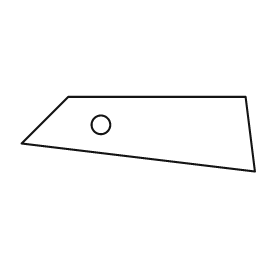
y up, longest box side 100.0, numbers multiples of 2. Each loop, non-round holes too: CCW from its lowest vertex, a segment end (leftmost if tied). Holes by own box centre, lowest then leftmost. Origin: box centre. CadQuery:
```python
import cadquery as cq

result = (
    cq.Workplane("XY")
    .moveTo(50.0, -16.0)
    .lineTo(46.0, 16.0)
    .lineTo(-30.0, 16.0)
    .lineTo(-50.0, -4.0)
    .close()
    .moveTo(-16.0, 4.0)
    .circle(4.0)
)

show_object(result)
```